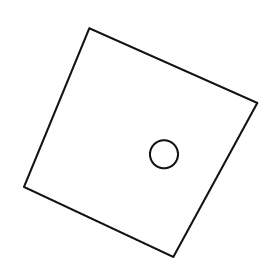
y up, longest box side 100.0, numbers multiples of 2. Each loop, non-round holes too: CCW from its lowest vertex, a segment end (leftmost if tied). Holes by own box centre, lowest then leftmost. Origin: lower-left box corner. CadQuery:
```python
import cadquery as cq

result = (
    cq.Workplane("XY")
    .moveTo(64.0, 0.0)
    .lineTo(100.0, 66.0)
    .lineTo(28.0, 98.0)
    .lineTo(0.0, 30.0)
    .close()
    .moveTo(60.0, 44.0)
    .circle(6.0)
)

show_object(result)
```